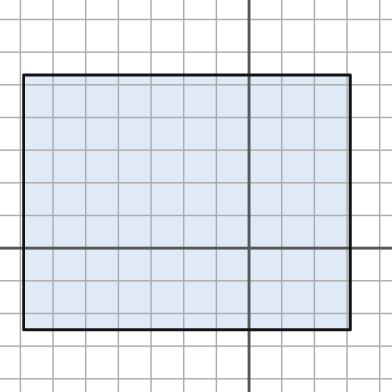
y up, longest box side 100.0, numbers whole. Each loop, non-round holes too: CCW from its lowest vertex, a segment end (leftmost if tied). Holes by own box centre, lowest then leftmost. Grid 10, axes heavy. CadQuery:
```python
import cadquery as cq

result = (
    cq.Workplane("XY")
    .moveTo(-69.0, -25.0)
    .lineTo(31.0, -25.0)
    .lineTo(31.0, 53.0)
    .lineTo(-69.0, 53.0)
    .close()
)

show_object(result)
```